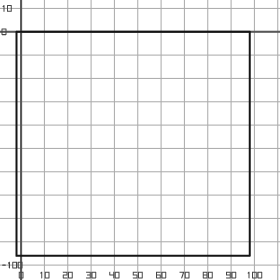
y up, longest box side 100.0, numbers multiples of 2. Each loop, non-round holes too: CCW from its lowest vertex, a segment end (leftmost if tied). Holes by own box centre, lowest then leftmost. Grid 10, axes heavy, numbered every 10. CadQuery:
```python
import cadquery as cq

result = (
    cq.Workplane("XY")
    .moveTo(-2.0, -96.0)
    .lineTo(98.0, -96.0)
    .lineTo(98.0, 0.0)
    .lineTo(-2.0, 0.0)
    .close()
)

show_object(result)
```